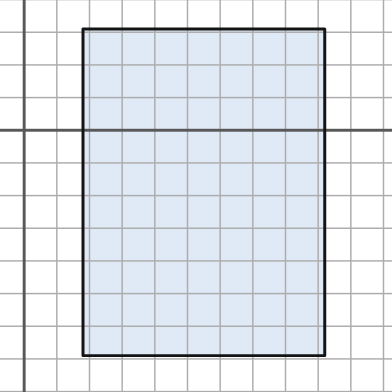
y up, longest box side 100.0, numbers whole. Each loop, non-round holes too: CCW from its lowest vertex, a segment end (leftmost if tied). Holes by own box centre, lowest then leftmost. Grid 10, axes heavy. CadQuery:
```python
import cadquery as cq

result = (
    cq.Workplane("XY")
    .moveTo(18.0, -69.0)
    .lineTo(92.0, -69.0)
    .lineTo(92.0, 31.0)
    .lineTo(18.0, 31.0)
    .close()
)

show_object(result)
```